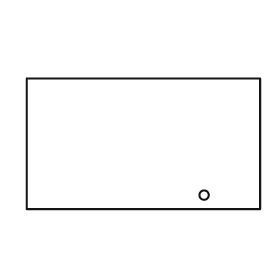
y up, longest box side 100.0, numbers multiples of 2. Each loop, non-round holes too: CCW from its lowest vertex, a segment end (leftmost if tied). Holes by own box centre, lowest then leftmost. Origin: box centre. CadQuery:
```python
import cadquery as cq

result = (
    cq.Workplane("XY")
    .moveTo(-50.0, -28.0)
    .lineTo(50.0, -28.0)
    .lineTo(50.0, 28.0)
    .lineTo(-50.0, 28.0)
    .close()
    .moveTo(26.0, -22.0)
    .circle(2.0)
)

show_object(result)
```